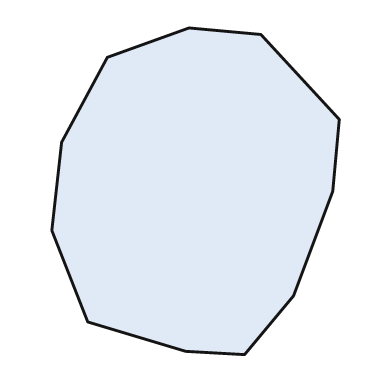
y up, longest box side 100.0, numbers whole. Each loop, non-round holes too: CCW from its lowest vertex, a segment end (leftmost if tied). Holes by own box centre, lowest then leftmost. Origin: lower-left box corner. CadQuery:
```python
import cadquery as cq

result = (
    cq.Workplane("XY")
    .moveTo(59.0, 0.0)
    .lineTo(74.0, 18.0)
    .lineTo(86.0, 50.0)
    .lineTo(88.0, 72.0)
    .lineTo(64.0, 98.0)
    .lineTo(42.0, 100.0)
    .lineTo(17.0, 91.0)
    .lineTo(3.0, 65.0)
    .lineTo(0.0, 38.0)
    .lineTo(11.0, 10.0)
    .lineTo(41.0, 1.0)
    .close()
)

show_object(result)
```